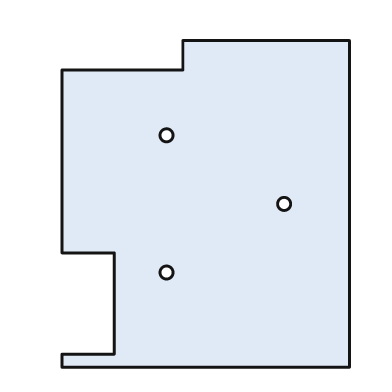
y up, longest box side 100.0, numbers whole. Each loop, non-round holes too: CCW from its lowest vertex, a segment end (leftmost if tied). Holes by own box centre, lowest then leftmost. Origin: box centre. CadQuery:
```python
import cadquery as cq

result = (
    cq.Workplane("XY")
    .moveTo(-44.0, -50.0)
    .lineTo(44.0, -50.0)
    .lineTo(44.0, 50.0)
    .lineTo(-7.0, 50.0)
    .lineTo(-7.0, 41.0)
    .lineTo(-44.0, 41.0)
    .lineTo(-44.0, -15.0)
    .lineTo(-28.0, -15.0)
    .lineTo(-28.0, -46.0)
    .lineTo(-44.0, -46.0)
    .close()
    .moveTo(-12.0, -21.0)
    .circle(2.0)
    .moveTo(24.0, 0.0)
    .circle(2.0)
    .moveTo(-12.0, 21.0)
    .circle(2.0)
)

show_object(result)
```